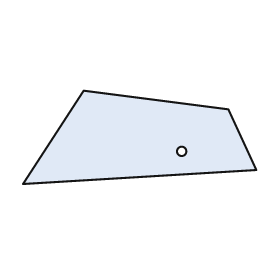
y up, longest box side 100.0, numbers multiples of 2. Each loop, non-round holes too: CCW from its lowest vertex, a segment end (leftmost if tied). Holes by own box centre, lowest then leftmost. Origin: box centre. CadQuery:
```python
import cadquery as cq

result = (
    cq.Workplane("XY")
    .moveTo(-50.0, -20.0)
    .lineTo(50.0, -14.0)
    .lineTo(38.0, 12.0)
    .lineTo(-24.0, 20.0)
    .close()
    .moveTo(18.0, -6.0)
    .circle(2.0)
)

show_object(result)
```